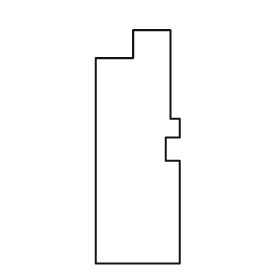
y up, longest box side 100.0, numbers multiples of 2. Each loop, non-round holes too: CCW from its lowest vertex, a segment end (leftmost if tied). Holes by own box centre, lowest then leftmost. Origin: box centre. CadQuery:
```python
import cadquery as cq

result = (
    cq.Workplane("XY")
    .moveTo(-18.0, -50.0)
    .lineTo(18.0, -50.0)
    .lineTo(18.0, -6.0)
    .lineTo(12.0, -6.0)
    .lineTo(12.0, 4.0)
    .lineTo(18.0, 4.0)
    .lineTo(18.0, 12.0)
    .lineTo(14.0, 12.0)
    .lineTo(14.0, 50.0)
    .lineTo(-2.0, 50.0)
    .lineTo(-2.0, 38.0)
    .lineTo(-18.0, 38.0)
    .close()
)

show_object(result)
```